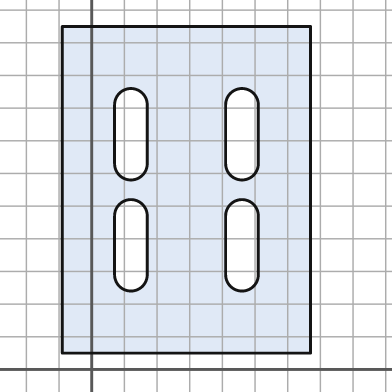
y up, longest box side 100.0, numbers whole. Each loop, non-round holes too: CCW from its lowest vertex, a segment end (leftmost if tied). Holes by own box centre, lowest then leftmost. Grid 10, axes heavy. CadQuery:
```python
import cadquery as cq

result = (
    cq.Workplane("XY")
    .moveTo(-9.0, 5.0)
    .lineTo(67.0, 5.0)
    .lineTo(67.0, 105.0)
    .lineTo(-9.0, 105.0)
    .close()
    .moveTo(7.0, 29.0)
    .threePointArc((12.0, 24.0), (17.0, 29.0))
    .lineTo(17.0, 47.0)
    .threePointArc((12.0, 52.0), (7.0, 47.0))
    .close()
    .moveTo(41.0, 29.0)
    .threePointArc((46.0, 24.0), (51.0, 29.0))
    .lineTo(51.0, 47.0)
    .threePointArc((46.0, 52.0), (41.0, 47.0))
    .close()
    .moveTo(7.0, 63.0)
    .threePointArc((12.0, 58.0), (17.0, 63.0))
    .lineTo(17.0, 81.0)
    .threePointArc((12.0, 86.0), (7.0, 81.0))
    .close()
    .moveTo(41.0, 63.0)
    .threePointArc((46.0, 58.0), (51.0, 63.0))
    .lineTo(51.0, 81.0)
    .threePointArc((46.0, 86.0), (41.0, 81.0))
    .close()
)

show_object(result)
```